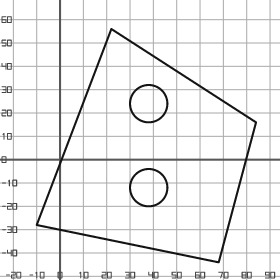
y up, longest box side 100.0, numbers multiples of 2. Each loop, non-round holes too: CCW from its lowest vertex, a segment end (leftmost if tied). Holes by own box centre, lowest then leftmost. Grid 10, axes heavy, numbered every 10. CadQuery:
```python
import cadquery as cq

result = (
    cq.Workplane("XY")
    .moveTo(68.0, -44.0)
    .lineTo(84.0, 16.0)
    .lineTo(22.0, 56.0)
    .lineTo(-10.0, -28.0)
    .close()
    .moveTo(38.0, -12.0)
    .circle(8.0)
    .moveTo(38.0, 24.0)
    .circle(8.0)
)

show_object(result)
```